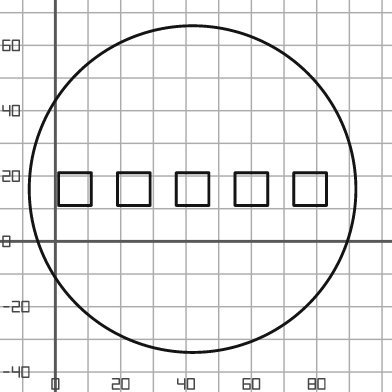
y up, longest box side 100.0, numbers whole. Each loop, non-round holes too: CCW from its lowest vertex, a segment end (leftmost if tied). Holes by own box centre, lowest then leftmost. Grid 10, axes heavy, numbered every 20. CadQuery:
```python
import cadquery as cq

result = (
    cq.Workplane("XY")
    .moveTo(42.0, 16.0)
    .circle(50.0)
    .moveTo(1.0, 11.0)
    .lineTo(11.0, 11.0)
    .lineTo(11.0, 21.0)
    .lineTo(1.0, 21.0)
    .close()
    .moveTo(19.0, 11.0)
    .lineTo(29.0, 11.0)
    .lineTo(29.0, 21.0)
    .lineTo(19.0, 21.0)
    .close()
    .moveTo(37.0, 11.0)
    .lineTo(47.0, 11.0)
    .lineTo(47.0, 21.0)
    .lineTo(37.0, 21.0)
    .close()
    .moveTo(55.0, 11.0)
    .lineTo(65.0, 11.0)
    .lineTo(65.0, 21.0)
    .lineTo(55.0, 21.0)
    .close()
    .moveTo(73.0, 11.0)
    .lineTo(83.0, 11.0)
    .lineTo(83.0, 21.0)
    .lineTo(73.0, 21.0)
    .close()
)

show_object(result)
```